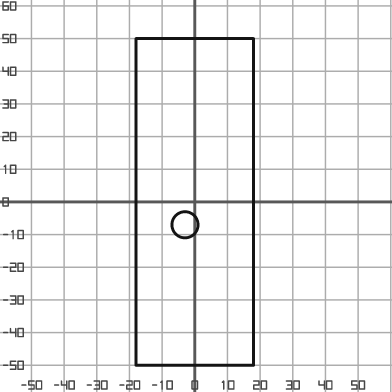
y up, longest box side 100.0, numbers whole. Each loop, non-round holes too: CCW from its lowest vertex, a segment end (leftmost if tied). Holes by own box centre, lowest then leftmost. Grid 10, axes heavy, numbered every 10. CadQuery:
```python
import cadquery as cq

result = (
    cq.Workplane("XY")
    .moveTo(-18.0, -50.0)
    .lineTo(18.0, -50.0)
    .lineTo(18.0, 50.0)
    .lineTo(-18.0, 50.0)
    .close()
    .moveTo(-3.0, -7.0)
    .circle(4.0)
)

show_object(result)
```